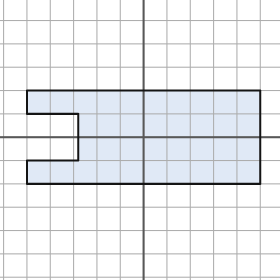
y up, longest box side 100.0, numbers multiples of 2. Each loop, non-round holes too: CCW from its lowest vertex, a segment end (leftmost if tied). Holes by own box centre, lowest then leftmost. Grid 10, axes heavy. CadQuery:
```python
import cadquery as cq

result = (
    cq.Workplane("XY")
    .moveTo(-50.0, -20.0)
    .lineTo(50.0, -20.0)
    .lineTo(50.0, 20.0)
    .lineTo(-50.0, 20.0)
    .lineTo(-50.0, 10.0)
    .lineTo(-28.0, 10.0)
    .lineTo(-28.0, -10.0)
    .lineTo(-50.0, -10.0)
    .close()
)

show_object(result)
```